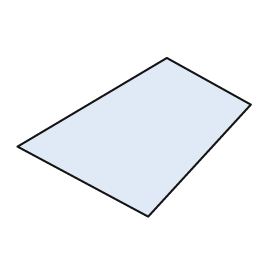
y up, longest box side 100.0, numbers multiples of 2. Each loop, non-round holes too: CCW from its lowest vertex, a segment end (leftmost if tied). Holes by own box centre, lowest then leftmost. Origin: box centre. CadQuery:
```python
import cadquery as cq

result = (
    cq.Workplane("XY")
    .moveTo(6.0, -34.0)
    .lineTo(50.0, 14.0)
    .lineTo(14.0, 34.0)
    .lineTo(-50.0, -4.0)
    .close()
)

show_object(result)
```